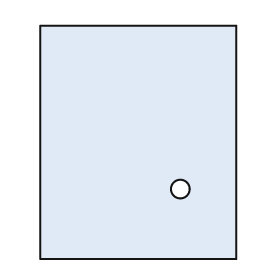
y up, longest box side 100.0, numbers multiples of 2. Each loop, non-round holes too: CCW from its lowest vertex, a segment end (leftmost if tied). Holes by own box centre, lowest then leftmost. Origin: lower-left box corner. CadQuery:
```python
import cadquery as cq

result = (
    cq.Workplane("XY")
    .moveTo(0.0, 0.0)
    .lineTo(84.0, 0.0)
    .lineTo(84.0, 100.0)
    .lineTo(0.0, 100.0)
    .close()
    .moveTo(60.0, 30.0)
    .circle(4.0)
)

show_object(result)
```